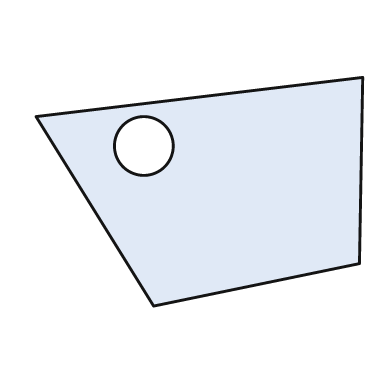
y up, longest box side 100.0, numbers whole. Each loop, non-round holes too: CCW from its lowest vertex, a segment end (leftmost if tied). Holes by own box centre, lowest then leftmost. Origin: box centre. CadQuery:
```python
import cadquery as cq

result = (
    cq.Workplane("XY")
    .moveTo(-14.0, -35.0)
    .lineTo(49.0, -22.0)
    .lineTo(50.0, 35.0)
    .lineTo(-50.0, 23.0)
    .close()
    .moveTo(-17.0, 14.0)
    .circle(9.0)
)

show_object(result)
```